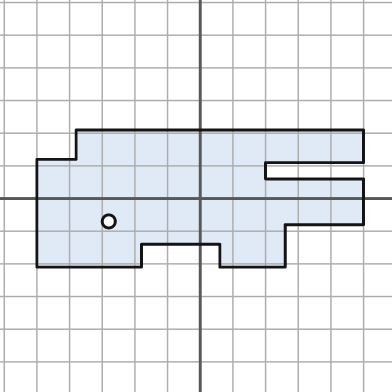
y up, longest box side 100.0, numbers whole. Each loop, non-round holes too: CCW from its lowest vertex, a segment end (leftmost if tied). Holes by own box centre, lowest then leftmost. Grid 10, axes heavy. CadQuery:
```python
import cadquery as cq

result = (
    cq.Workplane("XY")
    .moveTo(-50.0, -21.0)
    .lineTo(-18.0, -21.0)
    .lineTo(-18.0, -14.0)
    .lineTo(6.0, -14.0)
    .lineTo(6.0, -21.0)
    .lineTo(26.0, -21.0)
    .lineTo(26.0, -8.0)
    .lineTo(50.0, -8.0)
    .lineTo(50.0, 6.0)
    .lineTo(20.0, 6.0)
    .lineTo(20.0, 11.0)
    .lineTo(50.0, 11.0)
    .lineTo(50.0, 21.0)
    .lineTo(-38.0, 21.0)
    .lineTo(-38.0, 12.0)
    .lineTo(-50.0, 12.0)
    .close()
    .moveTo(-28.0, -7.0)
    .circle(2.0)
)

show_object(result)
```